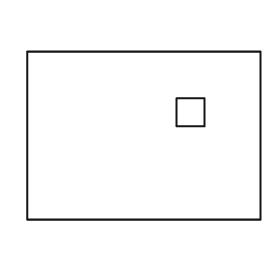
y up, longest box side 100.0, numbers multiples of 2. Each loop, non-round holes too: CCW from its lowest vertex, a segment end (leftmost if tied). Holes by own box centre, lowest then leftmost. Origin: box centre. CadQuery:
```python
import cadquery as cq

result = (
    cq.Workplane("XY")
    .moveTo(-50.0, -36.0)
    .lineTo(50.0, -36.0)
    .lineTo(50.0, 36.0)
    .lineTo(-50.0, 36.0)
    .close()
    .moveTo(14.0, 4.0)
    .lineTo(26.0, 4.0)
    .lineTo(26.0, 16.0)
    .lineTo(14.0, 16.0)
    .close()
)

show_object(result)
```